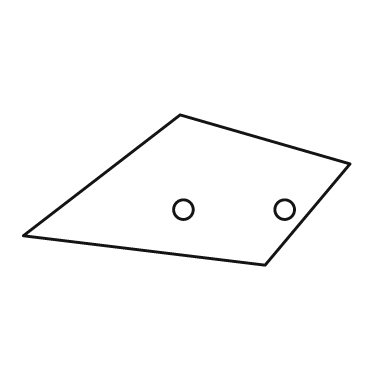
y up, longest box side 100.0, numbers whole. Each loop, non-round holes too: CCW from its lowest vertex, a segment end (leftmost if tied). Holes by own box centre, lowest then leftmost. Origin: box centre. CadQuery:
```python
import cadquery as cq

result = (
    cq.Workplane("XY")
    .moveTo(24.0, -23.0)
    .lineTo(50.0, 8.0)
    .lineTo(-2.0, 23.0)
    .lineTo(-50.0, -14.0)
    .close()
    .moveTo(-1.0, -6.0)
    .circle(3.0)
    .moveTo(30.0, -6.0)
    .circle(3.0)
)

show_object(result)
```